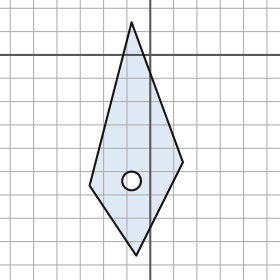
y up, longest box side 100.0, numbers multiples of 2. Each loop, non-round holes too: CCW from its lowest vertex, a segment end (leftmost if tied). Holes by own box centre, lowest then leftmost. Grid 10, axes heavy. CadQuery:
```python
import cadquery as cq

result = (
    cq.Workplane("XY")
    .moveTo(-6.0, -86.0)
    .lineTo(14.0, -46.0)
    .lineTo(-8.0, 14.0)
    .lineTo(-26.0, -56.0)
    .close()
    .moveTo(-8.0, -54.0)
    .circle(4.0)
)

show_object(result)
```